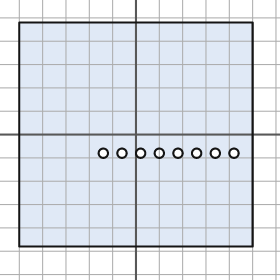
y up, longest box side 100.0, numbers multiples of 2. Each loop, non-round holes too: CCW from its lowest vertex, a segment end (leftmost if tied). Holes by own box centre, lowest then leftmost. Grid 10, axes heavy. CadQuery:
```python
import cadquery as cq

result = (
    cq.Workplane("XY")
    .moveTo(-50.0, -48.0)
    .lineTo(50.0, -48.0)
    .lineTo(50.0, 48.0)
    .lineTo(-50.0, 48.0)
    .close()
    .moveTo(-14.0, -8.0)
    .circle(2.0)
    .moveTo(-6.0, -8.0)
    .circle(2.0)
    .moveTo(2.0, -8.0)
    .circle(2.0)
    .moveTo(10.0, -8.0)
    .circle(2.0)
    .moveTo(18.0, -8.0)
    .circle(2.0)
    .moveTo(26.0, -8.0)
    .circle(2.0)
    .moveTo(34.0, -8.0)
    .circle(2.0)
    .moveTo(42.0, -8.0)
    .circle(2.0)
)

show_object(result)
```